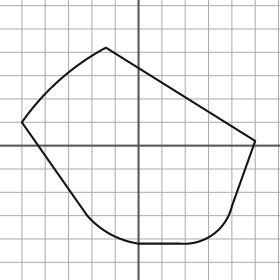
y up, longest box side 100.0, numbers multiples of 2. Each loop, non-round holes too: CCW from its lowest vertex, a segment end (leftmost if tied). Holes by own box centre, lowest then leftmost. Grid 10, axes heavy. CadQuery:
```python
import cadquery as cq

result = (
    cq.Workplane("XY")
    .moveTo(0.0, -42.0)
    .lineTo(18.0, -42.0)
    .threePointArc((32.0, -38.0), (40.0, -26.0))
    .lineTo(50.0, 2.0)
    .lineTo(-14.0, 42.0)
    .threePointArc((-34.0, 28.0), (-50.0, 10.0))
    .lineTo(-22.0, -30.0)
    .threePointArc((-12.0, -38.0), (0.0, -42.0))
    .close()
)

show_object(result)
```